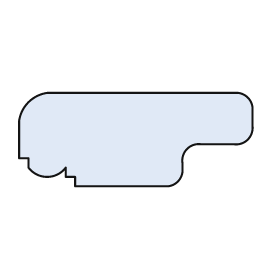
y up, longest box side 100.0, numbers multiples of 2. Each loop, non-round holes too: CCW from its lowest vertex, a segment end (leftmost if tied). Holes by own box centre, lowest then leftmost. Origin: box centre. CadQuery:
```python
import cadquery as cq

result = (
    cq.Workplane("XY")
    .moveTo(-26.0, -20.0)
    .lineTo(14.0, -20.0)
    .threePointArc((18.0, -18.0), (20.0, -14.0))
    .lineTo(20.0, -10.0)
    .threePointArc((22.0, -4.0), (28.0, -2.0))
    .lineTo(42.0, -2.0)
    .threePointArc((48.0, 0.0), (50.0, 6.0))
    .lineTo(50.0, 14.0)
    .threePointArc((48.0, 18.0), (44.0, 20.0))
    .lineTo(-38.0, 20.0)
    .threePointArc((-46.0, 16.0), (-50.0, 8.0))
    .lineTo(-50.0, -8.0)
    .lineTo(-46.0, -8.0)
    .lineTo(-46.0, -12.0)
    .threePointArc((-38.0, -16.0), (-30.0, -12.0))
    .lineTo(-30.0, -16.0)
    .lineTo(-26.0, -16.0)
    .close()
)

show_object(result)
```